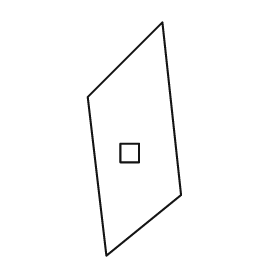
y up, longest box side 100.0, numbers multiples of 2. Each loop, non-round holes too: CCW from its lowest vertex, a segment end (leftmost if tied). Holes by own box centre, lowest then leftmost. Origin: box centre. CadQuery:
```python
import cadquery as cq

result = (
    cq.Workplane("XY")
    .moveTo(-12.0, -50.0)
    .lineTo(20.0, -24.0)
    .lineTo(12.0, 50.0)
    .lineTo(-20.0, 18.0)
    .close()
    .moveTo(-6.0, -10.0)
    .lineTo(2.0, -10.0)
    .lineTo(2.0, -2.0)
    .lineTo(-6.0, -2.0)
    .close()
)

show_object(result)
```